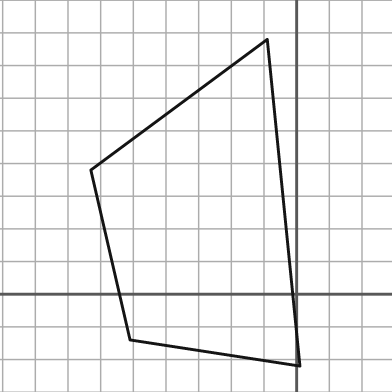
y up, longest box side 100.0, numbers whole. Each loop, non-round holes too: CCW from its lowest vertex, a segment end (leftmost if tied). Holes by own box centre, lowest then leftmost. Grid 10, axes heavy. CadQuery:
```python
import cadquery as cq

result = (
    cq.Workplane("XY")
    .moveTo(1.0, -22.0)
    .lineTo(-9.0, 78.0)
    .lineTo(-63.0, 38.0)
    .lineTo(-51.0, -14.0)
    .close()
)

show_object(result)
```